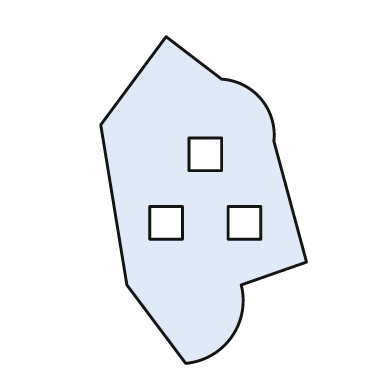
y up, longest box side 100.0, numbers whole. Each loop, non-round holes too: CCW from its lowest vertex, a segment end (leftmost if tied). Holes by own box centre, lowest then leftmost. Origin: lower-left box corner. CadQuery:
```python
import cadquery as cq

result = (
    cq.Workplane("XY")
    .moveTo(26.0, 0.0)
    .threePointArc((40.0, 8.0), (43.0, 24.0))
    .lineTo(63.0, 31.0)
    .lineTo(53.0, 68.0)
    .threePointArc((49.0, 81.0), (37.0, 87.0))
    .lineTo(20.0, 100.0)
    .lineTo(0.0, 73.0)
    .lineTo(8.0, 24.0)
    .close()
    .moveTo(15.0, 38.0)
    .lineTo(25.0, 38.0)
    .lineTo(25.0, 48.0)
    .lineTo(15.0, 48.0)
    .close()
    .moveTo(39.0, 38.0)
    .lineTo(49.0, 38.0)
    .lineTo(49.0, 48.0)
    .lineTo(39.0, 48.0)
    .close()
    .moveTo(27.0, 59.0)
    .lineTo(37.0, 59.0)
    .lineTo(37.0, 69.0)
    .lineTo(27.0, 69.0)
    .close()
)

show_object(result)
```